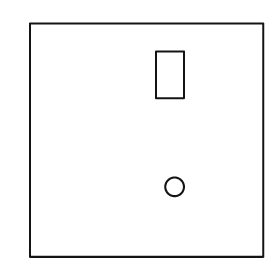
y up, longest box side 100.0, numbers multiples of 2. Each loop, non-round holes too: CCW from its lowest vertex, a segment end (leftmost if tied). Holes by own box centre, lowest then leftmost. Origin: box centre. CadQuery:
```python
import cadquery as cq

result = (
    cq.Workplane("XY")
    .moveTo(-50.0, -50.0)
    .lineTo(50.0, -50.0)
    .lineTo(50.0, 50.0)
    .lineTo(-50.0, 50.0)
    .close()
    .moveTo(12.0, -20.0)
    .circle(4.0)
    .moveTo(4.0, 18.0)
    .lineTo(16.0, 18.0)
    .lineTo(16.0, 38.0)
    .lineTo(4.0, 38.0)
    .close()
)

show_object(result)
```